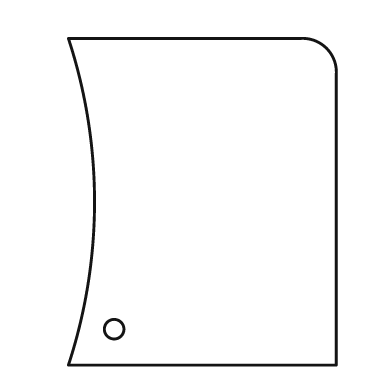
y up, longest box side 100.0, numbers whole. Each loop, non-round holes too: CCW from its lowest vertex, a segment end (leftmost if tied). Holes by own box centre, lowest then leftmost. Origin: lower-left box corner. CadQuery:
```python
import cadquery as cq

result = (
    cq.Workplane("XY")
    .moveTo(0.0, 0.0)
    .lineTo(82.0, 0.0)
    .lineTo(82.0, 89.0)
    .threePointArc((79.0, 97.0), (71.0, 100.0))
    .lineTo(0.0, 100.0)
    .threePointArc((8.0, 50.0), (0.0, 0.0))
    .close()
    .moveTo(14.0, 11.0)
    .circle(3.0)
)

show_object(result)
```